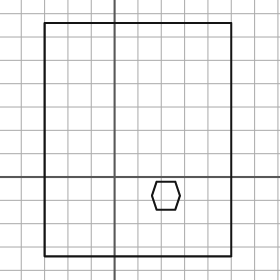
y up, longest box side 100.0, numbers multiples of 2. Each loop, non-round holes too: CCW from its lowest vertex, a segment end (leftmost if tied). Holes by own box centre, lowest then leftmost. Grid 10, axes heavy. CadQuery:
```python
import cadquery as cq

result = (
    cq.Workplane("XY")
    .moveTo(-30.0, -34.0)
    .lineTo(50.0, -34.0)
    .lineTo(50.0, 66.0)
    .lineTo(-30.0, 66.0)
    .close()
    .moveTo(18.0, -14.0)
    .lineTo(26.0, -14.0)
    .lineTo(28.0, -8.0)
    .lineTo(26.0, -2.0)
    .lineTo(18.0, -2.0)
    .lineTo(16.0, -8.0)
    .close()
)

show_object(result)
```